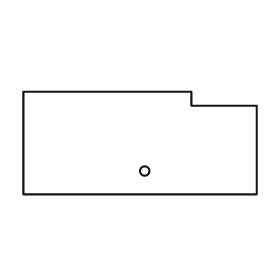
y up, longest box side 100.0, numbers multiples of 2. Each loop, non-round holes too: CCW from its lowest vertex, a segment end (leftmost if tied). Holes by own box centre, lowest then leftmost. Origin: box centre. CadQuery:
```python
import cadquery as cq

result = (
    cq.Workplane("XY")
    .moveTo(-50.0, -22.0)
    .lineTo(50.0, -22.0)
    .lineTo(50.0, 16.0)
    .lineTo(22.0, 16.0)
    .lineTo(22.0, 22.0)
    .lineTo(-50.0, 22.0)
    .close()
    .moveTo(2.0, -12.0)
    .circle(2.0)
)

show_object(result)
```